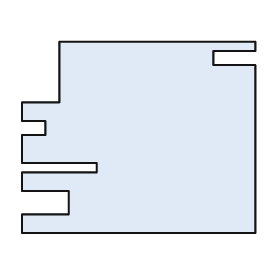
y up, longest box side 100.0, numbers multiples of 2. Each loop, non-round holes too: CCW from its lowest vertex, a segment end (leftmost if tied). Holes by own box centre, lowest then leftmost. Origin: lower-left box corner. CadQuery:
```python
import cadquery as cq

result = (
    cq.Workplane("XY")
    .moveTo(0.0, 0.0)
    .lineTo(100.0, 0.0)
    .lineTo(100.0, 72.0)
    .lineTo(82.0, 72.0)
    .lineTo(82.0, 78.0)
    .lineTo(100.0, 78.0)
    .lineTo(100.0, 82.0)
    .lineTo(16.0, 82.0)
    .lineTo(16.0, 56.0)
    .lineTo(0.0, 56.0)
    .lineTo(0.0, 48.0)
    .lineTo(10.0, 48.0)
    .lineTo(10.0, 42.0)
    .lineTo(0.0, 42.0)
    .lineTo(0.0, 30.0)
    .lineTo(32.0, 30.0)
    .lineTo(32.0, 26.0)
    .lineTo(0.0, 26.0)
    .lineTo(0.0, 18.0)
    .lineTo(20.0, 18.0)
    .lineTo(20.0, 8.0)
    .lineTo(0.0, 8.0)
    .close()
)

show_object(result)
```